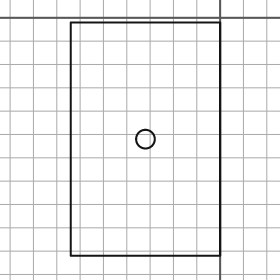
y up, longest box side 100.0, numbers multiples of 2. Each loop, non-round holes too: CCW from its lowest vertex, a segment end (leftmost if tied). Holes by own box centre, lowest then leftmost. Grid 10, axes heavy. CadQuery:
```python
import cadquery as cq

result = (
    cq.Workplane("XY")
    .moveTo(-64.0, -102.0)
    .lineTo(0.0, -102.0)
    .lineTo(0.0, -2.0)
    .lineTo(-64.0, -2.0)
    .close()
    .moveTo(-32.0, -52.0)
    .circle(4.0)
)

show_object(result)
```